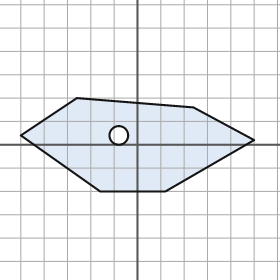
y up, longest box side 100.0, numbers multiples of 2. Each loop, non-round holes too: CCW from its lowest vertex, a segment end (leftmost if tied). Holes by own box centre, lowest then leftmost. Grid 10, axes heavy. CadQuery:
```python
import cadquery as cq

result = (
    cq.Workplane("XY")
    .moveTo(-16.0, -20.0)
    .lineTo(12.0, -20.0)
    .lineTo(50.0, 2.0)
    .lineTo(24.0, 16.0)
    .lineTo(-26.0, 20.0)
    .lineTo(-50.0, 4.0)
    .close()
    .moveTo(-8.0, 4.0)
    .circle(4.0)
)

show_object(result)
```